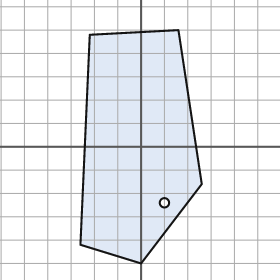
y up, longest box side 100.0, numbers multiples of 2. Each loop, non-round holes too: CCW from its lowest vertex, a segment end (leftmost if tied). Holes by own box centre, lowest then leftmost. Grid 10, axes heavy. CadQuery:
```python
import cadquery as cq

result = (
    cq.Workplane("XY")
    .moveTo(0.0, -50.0)
    .lineTo(26.0, -16.0)
    .lineTo(16.0, 50.0)
    .lineTo(-22.0, 48.0)
    .lineTo(-26.0, -42.0)
    .close()
    .moveTo(10.0, -24.0)
    .circle(2.0)
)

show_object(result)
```